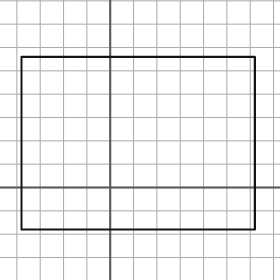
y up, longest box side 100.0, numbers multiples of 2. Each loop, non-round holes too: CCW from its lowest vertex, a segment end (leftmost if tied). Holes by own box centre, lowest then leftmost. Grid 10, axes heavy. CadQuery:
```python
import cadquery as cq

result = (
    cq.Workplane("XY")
    .moveTo(-38.0, -18.0)
    .lineTo(62.0, -18.0)
    .lineTo(62.0, 56.0)
    .lineTo(-38.0, 56.0)
    .close()
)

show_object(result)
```